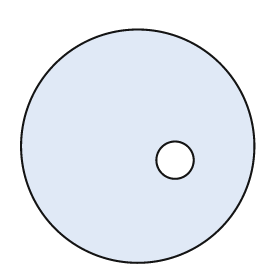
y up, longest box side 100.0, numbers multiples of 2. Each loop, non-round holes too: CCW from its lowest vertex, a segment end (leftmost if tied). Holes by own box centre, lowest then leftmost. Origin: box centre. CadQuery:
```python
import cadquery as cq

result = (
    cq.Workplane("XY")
    .moveTo(0.0, 0.0)
    .circle(50.0)
    .moveTo(16.0, -6.0)
    .circle(8.0)
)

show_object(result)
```